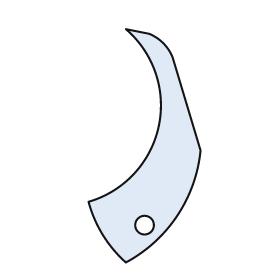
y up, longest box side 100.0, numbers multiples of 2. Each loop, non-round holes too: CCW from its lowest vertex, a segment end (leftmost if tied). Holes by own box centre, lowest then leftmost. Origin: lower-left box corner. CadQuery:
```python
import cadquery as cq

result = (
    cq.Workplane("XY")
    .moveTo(16.0, 0.0)
    .threePointArc((38.0, 20.0), (48.0, 48.0))
    .lineTo(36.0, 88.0)
    .threePointArc((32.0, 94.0), (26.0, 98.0))
    .lineTo(16.0, 100.0)
    .threePointArc((30.0, 58.0), (0.0, 26.0))
    .threePointArc((6.0, 12.0), (16.0, 0.0))
    .close()
    .moveTo(24.0, 16.0)
    .circle(4.0)
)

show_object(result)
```